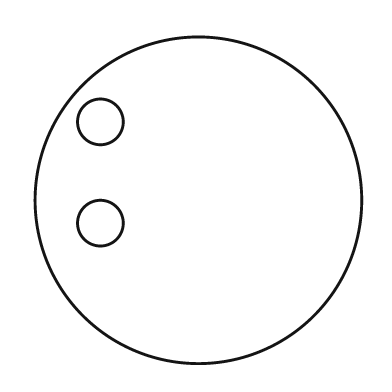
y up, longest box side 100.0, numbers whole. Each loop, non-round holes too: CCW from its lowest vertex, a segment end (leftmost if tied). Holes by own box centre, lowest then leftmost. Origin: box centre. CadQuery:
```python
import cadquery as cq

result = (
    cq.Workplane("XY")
    .moveTo(0.0, 0.0)
    .circle(50.0)
    .moveTo(-30.0, -7.0)
    .circle(7.0)
    .moveTo(-30.0, 24.0)
    .circle(7.0)
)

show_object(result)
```